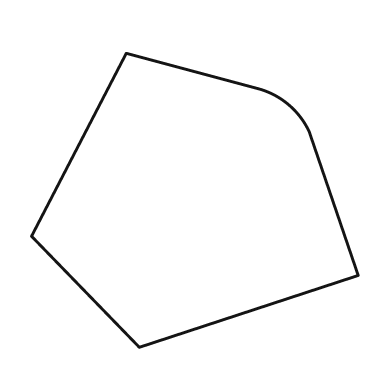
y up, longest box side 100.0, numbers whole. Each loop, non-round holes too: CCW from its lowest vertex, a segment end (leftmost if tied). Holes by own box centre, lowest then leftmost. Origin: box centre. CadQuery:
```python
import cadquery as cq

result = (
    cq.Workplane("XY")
    .moveTo(-17.0, -45.0)
    .lineTo(50.0, -23.0)
    .lineTo(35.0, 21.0)
    .threePointArc((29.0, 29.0), (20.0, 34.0))
    .lineTo(-21.0, 45.0)
    .lineTo(-50.0, -11.0)
    .close()
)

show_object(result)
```